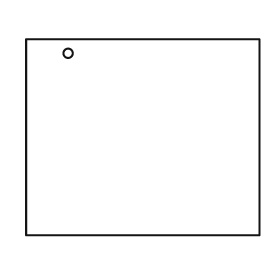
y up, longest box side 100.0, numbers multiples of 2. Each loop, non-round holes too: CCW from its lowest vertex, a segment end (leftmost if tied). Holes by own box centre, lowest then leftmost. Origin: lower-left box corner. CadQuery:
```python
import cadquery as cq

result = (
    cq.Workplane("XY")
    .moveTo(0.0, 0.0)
    .lineTo(100.0, 0.0)
    .lineTo(100.0, 84.0)
    .lineTo(0.0, 84.0)
    .close()
    .moveTo(18.0, 78.0)
    .circle(2.0)
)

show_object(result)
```